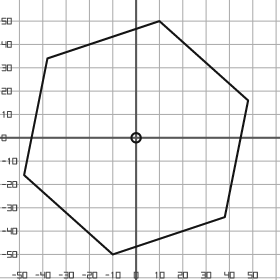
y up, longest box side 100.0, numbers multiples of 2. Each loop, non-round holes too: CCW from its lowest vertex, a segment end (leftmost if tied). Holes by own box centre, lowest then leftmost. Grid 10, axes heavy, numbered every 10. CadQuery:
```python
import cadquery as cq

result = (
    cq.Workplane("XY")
    .moveTo(-10.0, -50.0)
    .lineTo(38.0, -34.0)
    .lineTo(48.0, 16.0)
    .lineTo(10.0, 50.0)
    .lineTo(-38.0, 34.0)
    .lineTo(-48.0, -16.0)
    .close()
    .moveTo(0.0, 0.0)
    .circle(2.0)
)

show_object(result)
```